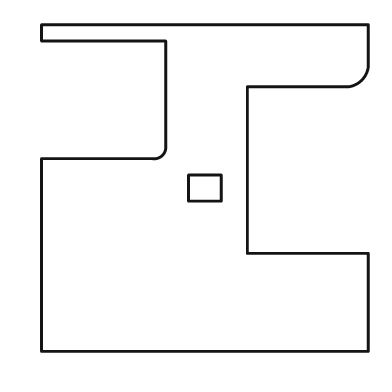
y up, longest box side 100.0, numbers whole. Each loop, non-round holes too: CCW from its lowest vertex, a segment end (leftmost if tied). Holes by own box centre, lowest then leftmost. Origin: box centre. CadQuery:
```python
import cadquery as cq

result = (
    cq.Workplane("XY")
    .moveTo(-50.0, -50.0)
    .lineTo(50.0, -50.0)
    .lineTo(50.0, -20.0)
    .lineTo(13.0, -20.0)
    .lineTo(13.0, 31.0)
    .lineTo(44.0, 31.0)
    .threePointArc((48.0, 33.0), (50.0, 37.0))
    .lineTo(50.0, 50.0)
    .lineTo(-50.0, 50.0)
    .lineTo(-50.0, 45.0)
    .lineTo(-12.0, 45.0)
    .lineTo(-12.0, 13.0)
    .threePointArc((-13.0, 10.0), (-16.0, 9.0))
    .lineTo(-50.0, 9.0)
    .close()
    .moveTo(-5.0, -4.0)
    .lineTo(5.0, -4.0)
    .lineTo(5.0, 4.0)
    .lineTo(-5.0, 4.0)
    .close()
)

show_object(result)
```